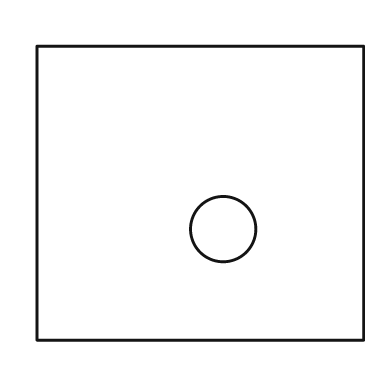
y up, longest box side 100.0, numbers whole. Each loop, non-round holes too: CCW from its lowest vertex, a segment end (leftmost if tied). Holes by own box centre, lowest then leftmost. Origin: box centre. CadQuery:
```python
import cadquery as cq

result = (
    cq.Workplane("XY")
    .moveTo(-50.0, -45.0)
    .lineTo(50.0, -45.0)
    .lineTo(50.0, 45.0)
    .lineTo(-50.0, 45.0)
    .close()
    .moveTo(7.0, -11.0)
    .circle(10.0)
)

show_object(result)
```